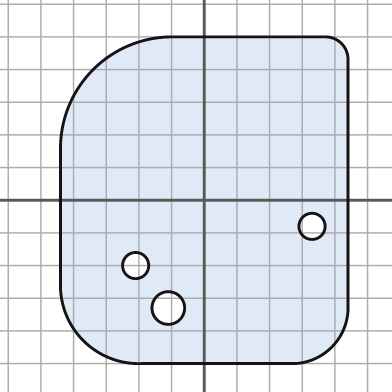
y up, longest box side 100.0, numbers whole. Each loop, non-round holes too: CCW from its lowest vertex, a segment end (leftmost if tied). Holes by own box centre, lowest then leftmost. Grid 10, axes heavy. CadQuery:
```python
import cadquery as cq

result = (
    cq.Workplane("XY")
    .moveTo(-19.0, -50.0)
    .lineTo(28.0, -50.0)
    .threePointArc((39.0, -45.0), (44.0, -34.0))
    .lineTo(44.0, 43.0)
    .threePointArc((42.0, 48.0), (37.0, 50.0))
    .lineTo(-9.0, 50.0)
    .threePointArc((-34.0, 40.0), (-44.0, 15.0))
    .lineTo(-44.0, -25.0)
    .threePointArc((-37.0, -43.0), (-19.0, -50.0))
    .close()
    .moveTo(-11.0, -33.0)
    .circle(5.0)
    .moveTo(-21.0, -20.0)
    .circle(4.0)
    .moveTo(33.0, -8.0)
    .circle(4.0)
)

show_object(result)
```